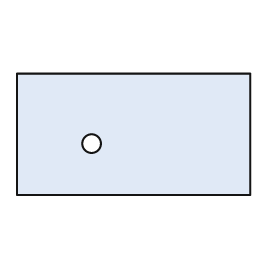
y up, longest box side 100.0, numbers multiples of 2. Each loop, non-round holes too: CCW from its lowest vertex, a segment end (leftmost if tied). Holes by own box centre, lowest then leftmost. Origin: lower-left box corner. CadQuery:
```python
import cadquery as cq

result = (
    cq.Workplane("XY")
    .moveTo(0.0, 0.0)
    .lineTo(100.0, 0.0)
    .lineTo(100.0, 52.0)
    .lineTo(0.0, 52.0)
    .close()
    .moveTo(32.0, 22.0)
    .circle(4.0)
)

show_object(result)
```